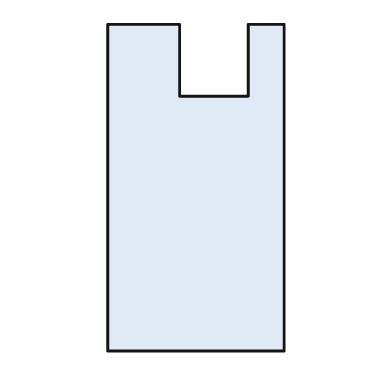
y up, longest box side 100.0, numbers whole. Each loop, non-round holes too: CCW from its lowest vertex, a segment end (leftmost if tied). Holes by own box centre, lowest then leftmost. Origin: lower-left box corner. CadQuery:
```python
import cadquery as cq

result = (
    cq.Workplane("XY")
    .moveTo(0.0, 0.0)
    .lineTo(54.0, 0.0)
    .lineTo(54.0, 100.0)
    .lineTo(43.0, 100.0)
    .lineTo(43.0, 78.0)
    .lineTo(22.0, 78.0)
    .lineTo(22.0, 100.0)
    .lineTo(0.0, 100.0)
    .close()
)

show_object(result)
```